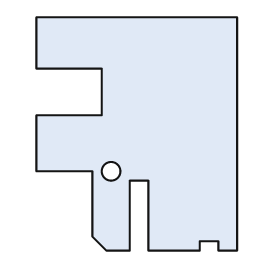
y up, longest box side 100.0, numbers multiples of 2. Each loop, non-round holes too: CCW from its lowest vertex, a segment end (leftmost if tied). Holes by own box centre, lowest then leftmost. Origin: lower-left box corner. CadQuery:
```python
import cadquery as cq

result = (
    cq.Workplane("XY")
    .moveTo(30.0, 0.0)
    .lineTo(40.0, 0.0)
    .lineTo(40.0, 30.0)
    .lineTo(48.0, 30.0)
    .lineTo(48.0, 0.0)
    .lineTo(70.0, 0.0)
    .lineTo(70.0, 4.0)
    .lineTo(78.0, 4.0)
    .lineTo(78.0, 0.0)
    .lineTo(86.0, 0.0)
    .lineTo(86.0, 100.0)
    .lineTo(0.0, 100.0)
    .lineTo(0.0, 78.0)
    .lineTo(28.0, 78.0)
    .lineTo(28.0, 58.0)
    .lineTo(0.0, 58.0)
    .lineTo(0.0, 34.0)
    .lineTo(24.0, 34.0)
    .lineTo(24.0, 6.0)
    .close()
    .moveTo(32.0, 34.0)
    .circle(4.0)
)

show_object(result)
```